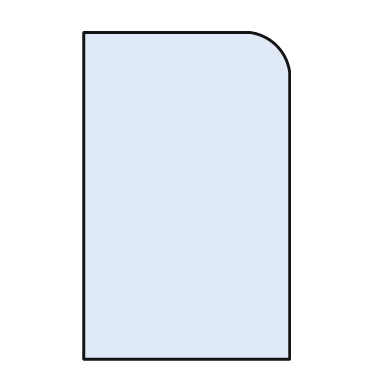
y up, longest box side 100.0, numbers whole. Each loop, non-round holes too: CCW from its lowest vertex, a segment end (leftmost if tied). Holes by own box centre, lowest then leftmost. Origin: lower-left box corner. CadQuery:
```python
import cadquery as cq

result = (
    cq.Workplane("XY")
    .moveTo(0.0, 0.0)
    .lineTo(63.0, 0.0)
    .lineTo(63.0, 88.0)
    .threePointArc((59.0, 96.0), (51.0, 100.0))
    .lineTo(0.0, 100.0)
    .close()
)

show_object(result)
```